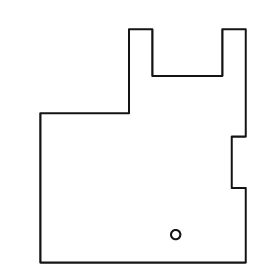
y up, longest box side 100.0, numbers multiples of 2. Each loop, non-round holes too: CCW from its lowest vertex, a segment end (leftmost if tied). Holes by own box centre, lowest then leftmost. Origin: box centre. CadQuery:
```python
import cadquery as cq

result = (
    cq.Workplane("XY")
    .moveTo(-44.0, -50.0)
    .lineTo(44.0, -50.0)
    .lineTo(44.0, -18.0)
    .lineTo(38.0, -18.0)
    .lineTo(38.0, 4.0)
    .lineTo(44.0, 4.0)
    .lineTo(44.0, 50.0)
    .lineTo(34.0, 50.0)
    .lineTo(34.0, 30.0)
    .lineTo(4.0, 30.0)
    .lineTo(4.0, 50.0)
    .lineTo(-6.0, 50.0)
    .lineTo(-6.0, 14.0)
    .lineTo(-44.0, 14.0)
    .close()
    .moveTo(14.0, -38.0)
    .circle(2.0)
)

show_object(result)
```